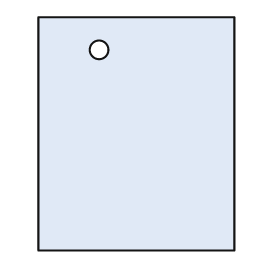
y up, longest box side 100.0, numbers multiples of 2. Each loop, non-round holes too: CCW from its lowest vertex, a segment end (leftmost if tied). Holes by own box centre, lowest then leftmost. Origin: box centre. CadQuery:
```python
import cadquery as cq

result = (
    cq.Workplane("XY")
    .moveTo(-42.0, -50.0)
    .lineTo(42.0, -50.0)
    .lineTo(42.0, 50.0)
    .lineTo(-42.0, 50.0)
    .close()
    .moveTo(-16.0, 36.0)
    .circle(4.0)
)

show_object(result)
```